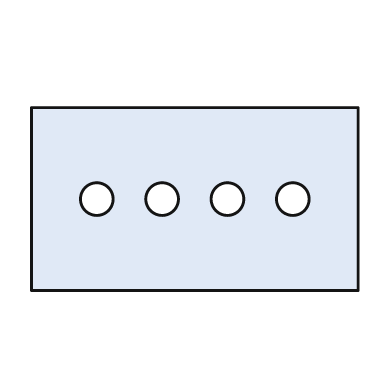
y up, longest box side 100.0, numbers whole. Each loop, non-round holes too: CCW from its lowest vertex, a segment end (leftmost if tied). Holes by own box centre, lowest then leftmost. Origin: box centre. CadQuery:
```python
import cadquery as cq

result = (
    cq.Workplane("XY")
    .moveTo(-50.0, -28.0)
    .lineTo(50.0, -28.0)
    .lineTo(50.0, 28.0)
    .lineTo(-50.0, 28.0)
    .close()
    .moveTo(-30.0, 0.0)
    .circle(5.0)
    .moveTo(-10.0, 0.0)
    .circle(5.0)
    .moveTo(10.0, 0.0)
    .circle(5.0)
    .moveTo(30.0, 0.0)
    .circle(5.0)
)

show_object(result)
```